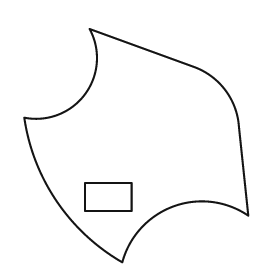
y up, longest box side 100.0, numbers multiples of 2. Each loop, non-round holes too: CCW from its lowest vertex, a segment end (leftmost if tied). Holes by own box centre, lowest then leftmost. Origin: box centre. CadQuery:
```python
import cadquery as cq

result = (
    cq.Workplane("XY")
    .moveTo(-6.0, -50.0)
    .threePointArc((16.0, -26.0), (48.0, -30.0))
    .lineTo(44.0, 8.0)
    .threePointArc((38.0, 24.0), (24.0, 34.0))
    .lineTo(-20.0, 50.0)
    .threePointArc((-22.0, 22.0), (-48.0, 12.0))
    .threePointArc((-34.0, -24.0), (-6.0, -50.0))
    .close()
    .moveTo(-22.0, -28.0)
    .lineTo(-2.0, -28.0)
    .lineTo(-2.0, -16.0)
    .lineTo(-22.0, -16.0)
    .close()
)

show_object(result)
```